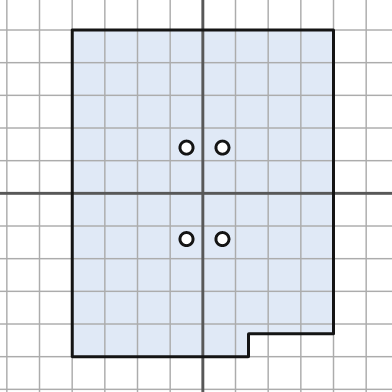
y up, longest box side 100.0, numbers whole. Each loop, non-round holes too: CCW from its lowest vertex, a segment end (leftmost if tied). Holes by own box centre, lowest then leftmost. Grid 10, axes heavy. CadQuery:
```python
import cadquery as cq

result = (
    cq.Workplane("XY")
    .moveTo(-40.0, -50.0)
    .lineTo(14.0, -50.0)
    .lineTo(14.0, -43.0)
    .lineTo(40.0, -43.0)
    .lineTo(40.0, 50.0)
    .lineTo(-40.0, 50.0)
    .close()
    .moveTo(-5.0, -14.0)
    .circle(2.0)
    .moveTo(6.0, -14.0)
    .circle(2.0)
    .moveTo(-5.0, 14.0)
    .circle(2.0)
    .moveTo(6.0, 14.0)
    .circle(2.0)
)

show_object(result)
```